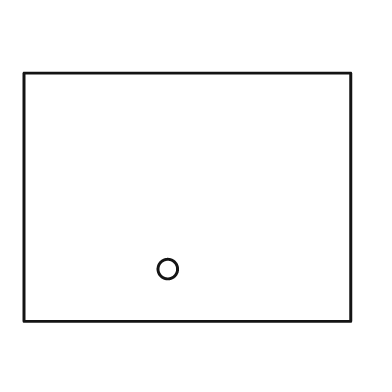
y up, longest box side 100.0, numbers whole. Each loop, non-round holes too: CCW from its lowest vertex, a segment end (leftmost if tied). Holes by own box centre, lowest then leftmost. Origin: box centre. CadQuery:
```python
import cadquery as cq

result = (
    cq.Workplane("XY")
    .moveTo(-50.0, -38.0)
    .lineTo(50.0, -38.0)
    .lineTo(50.0, 38.0)
    .lineTo(-50.0, 38.0)
    .close()
    .moveTo(-6.0, -22.0)
    .circle(3.0)
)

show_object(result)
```